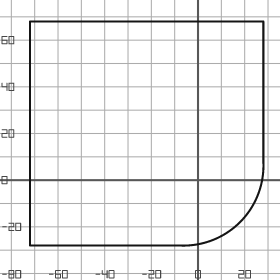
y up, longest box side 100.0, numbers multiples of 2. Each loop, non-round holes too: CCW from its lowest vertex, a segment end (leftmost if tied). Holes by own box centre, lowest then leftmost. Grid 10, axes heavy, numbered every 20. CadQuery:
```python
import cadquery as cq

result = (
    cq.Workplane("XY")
    .moveTo(-72.0, -28.0)
    .lineTo(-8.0, -28.0)
    .threePointArc((18.0, -18.0), (28.0, 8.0))
    .lineTo(28.0, 68.0)
    .lineTo(-72.0, 68.0)
    .close()
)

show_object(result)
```